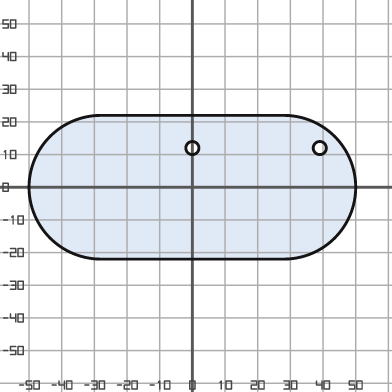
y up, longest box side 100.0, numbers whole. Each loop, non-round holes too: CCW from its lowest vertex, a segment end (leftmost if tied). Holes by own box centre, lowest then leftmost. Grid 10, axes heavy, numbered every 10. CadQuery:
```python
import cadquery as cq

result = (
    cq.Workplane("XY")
    .moveTo(-28.0, -22.0)
    .lineTo(28.0, -22.0)
    .threePointArc((50.0, 0.0), (28.0, 22.0))
    .lineTo(-28.0, 22.0)
    .threePointArc((-50.0, 0.0), (-28.0, -22.0))
    .close()
    .moveTo(0.0, 12.0)
    .circle(2.0)
    .moveTo(39.0, 12.0)
    .circle(2.0)
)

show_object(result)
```